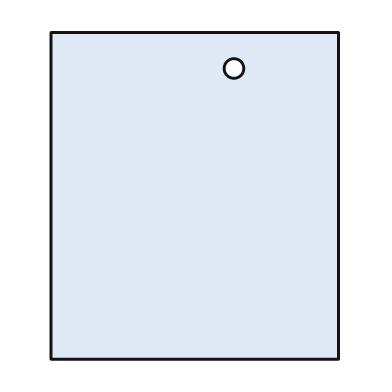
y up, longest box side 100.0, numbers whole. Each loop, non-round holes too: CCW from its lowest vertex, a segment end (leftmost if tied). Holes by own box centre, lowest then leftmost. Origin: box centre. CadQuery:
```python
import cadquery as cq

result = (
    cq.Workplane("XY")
    .moveTo(-44.0, -50.0)
    .lineTo(44.0, -50.0)
    .lineTo(44.0, 50.0)
    .lineTo(-44.0, 50.0)
    .close()
    .moveTo(12.0, 39.0)
    .circle(3.0)
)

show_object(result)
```